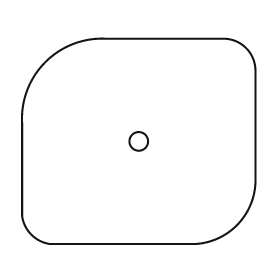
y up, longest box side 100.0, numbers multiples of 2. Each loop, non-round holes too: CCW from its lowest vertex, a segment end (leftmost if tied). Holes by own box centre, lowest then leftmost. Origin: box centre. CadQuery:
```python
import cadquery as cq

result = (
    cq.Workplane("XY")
    .moveTo(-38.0, -44.0)
    .lineTo(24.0, -44.0)
    .threePointArc((42.0, -36.0), (50.0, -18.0))
    .lineTo(50.0, 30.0)
    .threePointArc((46.0, 40.0), (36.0, 44.0))
    .lineTo(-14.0, 44.0)
    .threePointArc((-40.0, 34.0), (-50.0, 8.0))
    .lineTo(-50.0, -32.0)
    .threePointArc((-46.0, -40.0), (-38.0, -44.0))
    .close()
    .moveTo(0.0, 0.0)
    .circle(4.0)
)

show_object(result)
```